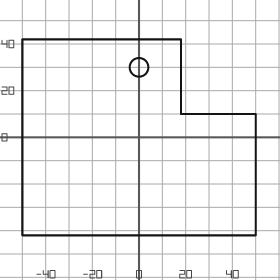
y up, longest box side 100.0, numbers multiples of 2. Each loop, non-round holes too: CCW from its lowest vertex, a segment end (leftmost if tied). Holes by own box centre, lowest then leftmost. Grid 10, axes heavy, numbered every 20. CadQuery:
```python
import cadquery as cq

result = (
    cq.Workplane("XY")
    .moveTo(-50.0, -42.0)
    .lineTo(50.0, -42.0)
    .lineTo(50.0, 10.0)
    .lineTo(18.0, 10.0)
    .lineTo(18.0, 42.0)
    .lineTo(-50.0, 42.0)
    .close()
    .moveTo(0.0, 30.0)
    .circle(4.0)
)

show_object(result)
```